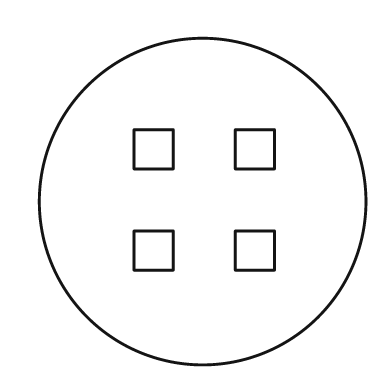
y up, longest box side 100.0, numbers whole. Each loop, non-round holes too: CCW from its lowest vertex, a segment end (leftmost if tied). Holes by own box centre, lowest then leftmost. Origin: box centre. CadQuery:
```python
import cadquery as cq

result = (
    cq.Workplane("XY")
    .moveTo(0.0, 0.0)
    .circle(50.0)
    .moveTo(-21.0, -21.0)
    .lineTo(-9.0, -21.0)
    .lineTo(-9.0, -9.0)
    .lineTo(-21.0, -9.0)
    .close()
    .moveTo(10.0, -21.0)
    .lineTo(22.0, -21.0)
    .lineTo(22.0, -9.0)
    .lineTo(10.0, -9.0)
    .close()
    .moveTo(-21.0, 10.0)
    .lineTo(-9.0, 10.0)
    .lineTo(-9.0, 22.0)
    .lineTo(-21.0, 22.0)
    .close()
    .moveTo(10.0, 10.0)
    .lineTo(22.0, 10.0)
    .lineTo(22.0, 22.0)
    .lineTo(10.0, 22.0)
    .close()
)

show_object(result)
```